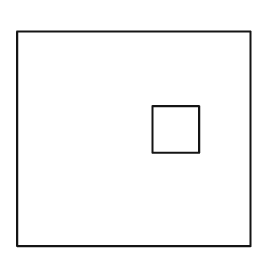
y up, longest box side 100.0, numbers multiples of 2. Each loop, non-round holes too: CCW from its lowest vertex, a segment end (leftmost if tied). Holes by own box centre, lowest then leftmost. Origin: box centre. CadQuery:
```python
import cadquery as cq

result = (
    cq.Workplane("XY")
    .moveTo(-50.0, -46.0)
    .lineTo(50.0, -46.0)
    .lineTo(50.0, 46.0)
    .lineTo(-50.0, 46.0)
    .close()
    .moveTo(8.0, -6.0)
    .lineTo(28.0, -6.0)
    .lineTo(28.0, 14.0)
    .lineTo(8.0, 14.0)
    .close()
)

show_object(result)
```